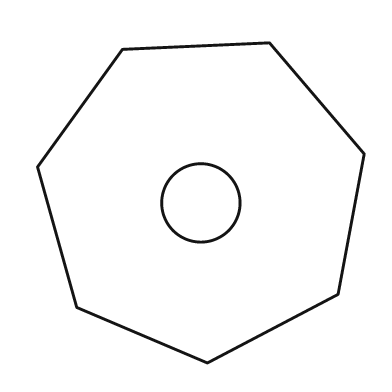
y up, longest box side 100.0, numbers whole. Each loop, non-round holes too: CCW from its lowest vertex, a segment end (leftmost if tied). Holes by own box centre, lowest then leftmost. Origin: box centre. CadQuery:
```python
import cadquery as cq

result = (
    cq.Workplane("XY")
    .moveTo(2.0, -49.0)
    .lineTo(42.0, -28.0)
    .lineTo(50.0, 15.0)
    .lineTo(21.0, 49.0)
    .lineTo(-24.0, 47.0)
    .lineTo(-50.0, 11.0)
    .lineTo(-38.0, -32.0)
    .close()
    .moveTo(0.0, 0.0)
    .circle(12.0)
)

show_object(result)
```